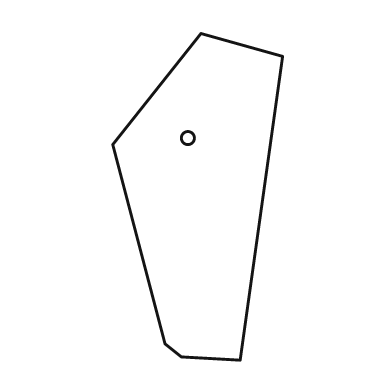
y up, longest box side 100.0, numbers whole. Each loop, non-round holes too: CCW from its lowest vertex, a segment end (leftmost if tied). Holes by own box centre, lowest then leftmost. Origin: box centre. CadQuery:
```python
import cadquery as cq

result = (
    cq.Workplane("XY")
    .moveTo(13.0, -50.0)
    .lineTo(26.0, 43.0)
    .lineTo(1.0, 50.0)
    .lineTo(-26.0, 16.0)
    .lineTo(-10.0, -45.0)
    .lineTo(-5.0, -49.0)
    .close()
    .moveTo(-3.0, 18.0)
    .circle(2.0)
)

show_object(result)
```